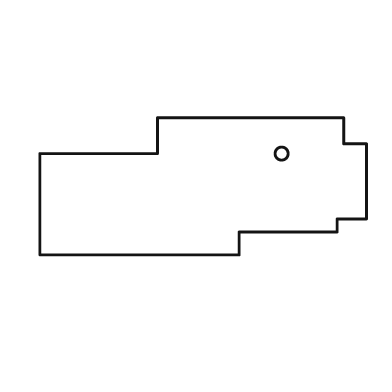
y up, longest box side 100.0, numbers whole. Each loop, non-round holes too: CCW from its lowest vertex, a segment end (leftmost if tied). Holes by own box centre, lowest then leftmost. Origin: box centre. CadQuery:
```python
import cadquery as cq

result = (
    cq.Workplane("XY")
    .moveTo(-50.0, -21.0)
    .lineTo(11.0, -21.0)
    .lineTo(11.0, -14.0)
    .lineTo(41.0, -14.0)
    .lineTo(41.0, -10.0)
    .lineTo(50.0, -10.0)
    .lineTo(50.0, 13.0)
    .lineTo(43.0, 13.0)
    .lineTo(43.0, 21.0)
    .lineTo(-14.0, 21.0)
    .lineTo(-14.0, 10.0)
    .lineTo(-50.0, 10.0)
    .close()
    .moveTo(24.0, 10.0)
    .circle(2.0)
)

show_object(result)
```